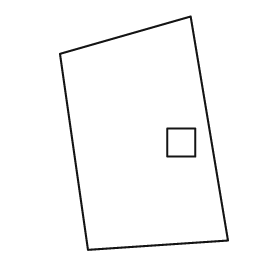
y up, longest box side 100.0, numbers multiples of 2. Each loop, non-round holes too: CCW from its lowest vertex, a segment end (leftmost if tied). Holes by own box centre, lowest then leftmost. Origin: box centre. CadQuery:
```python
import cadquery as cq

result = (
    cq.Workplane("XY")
    .moveTo(-24.0, -50.0)
    .lineTo(36.0, -46.0)
    .lineTo(20.0, 50.0)
    .lineTo(-36.0, 34.0)
    .close()
    .moveTo(10.0, -10.0)
    .lineTo(22.0, -10.0)
    .lineTo(22.0, 2.0)
    .lineTo(10.0, 2.0)
    .close()
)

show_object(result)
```